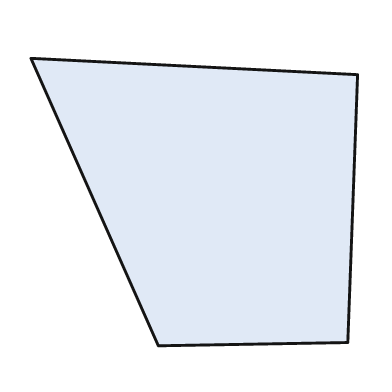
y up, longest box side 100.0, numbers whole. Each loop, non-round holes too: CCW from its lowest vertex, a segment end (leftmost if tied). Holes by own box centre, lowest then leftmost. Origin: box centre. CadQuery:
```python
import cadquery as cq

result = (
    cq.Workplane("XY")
    .moveTo(-11.0, -44.0)
    .lineTo(47.0, -43.0)
    .lineTo(50.0, 39.0)
    .lineTo(-50.0, 44.0)
    .close()
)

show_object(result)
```